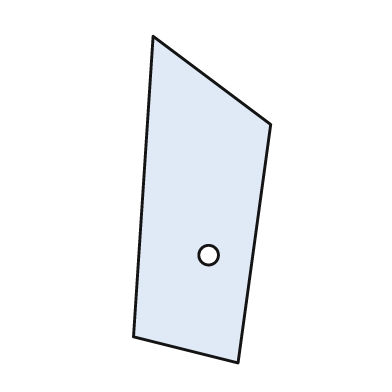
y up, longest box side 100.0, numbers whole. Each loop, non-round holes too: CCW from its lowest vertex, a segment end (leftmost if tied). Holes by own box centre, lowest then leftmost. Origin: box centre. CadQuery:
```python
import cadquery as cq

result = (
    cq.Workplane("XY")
    .moveTo(11.0, -50.0)
    .lineTo(21.0, 23.0)
    .lineTo(-15.0, 50.0)
    .lineTo(-21.0, -42.0)
    .close()
    .moveTo(2.0, -17.0)
    .circle(3.0)
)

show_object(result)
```